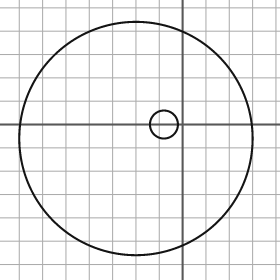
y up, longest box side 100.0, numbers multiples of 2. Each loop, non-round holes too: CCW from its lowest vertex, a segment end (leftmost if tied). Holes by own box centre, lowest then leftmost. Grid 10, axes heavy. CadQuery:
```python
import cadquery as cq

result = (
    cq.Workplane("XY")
    .moveTo(-20.0, -6.0)
    .circle(50.0)
    .moveTo(-8.0, 0.0)
    .circle(6.0)
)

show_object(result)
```